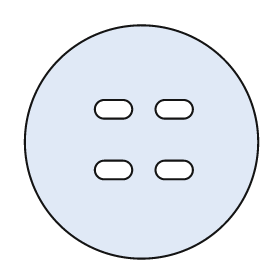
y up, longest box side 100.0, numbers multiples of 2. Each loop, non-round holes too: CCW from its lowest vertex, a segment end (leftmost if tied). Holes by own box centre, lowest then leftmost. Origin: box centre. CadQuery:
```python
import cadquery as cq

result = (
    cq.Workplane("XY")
    .moveTo(0.0, 0.0)
    .circle(50.0)
    .moveTo(-16.0, -16.0)
    .lineTo(-8.0, -16.0)
    .threePointArc((-4.0, -12.0), (-8.0, -8.0))
    .lineTo(-16.0, -8.0)
    .threePointArc((-20.0, -12.0), (-16.0, -16.0))
    .close()
    .moveTo(10.0, -16.0)
    .lineTo(18.0, -16.0)
    .threePointArc((22.0, -12.0), (18.0, -8.0))
    .lineTo(10.0, -8.0)
    .threePointArc((6.0, -12.0), (10.0, -16.0))
    .close()
    .moveTo(-16.0, 10.0)
    .lineTo(-8.0, 10.0)
    .threePointArc((-4.0, 14.0), (-8.0, 18.0))
    .lineTo(-16.0, 18.0)
    .threePointArc((-20.0, 14.0), (-16.0, 10.0))
    .close()
    .moveTo(10.0, 10.0)
    .lineTo(18.0, 10.0)
    .threePointArc((22.0, 14.0), (18.0, 18.0))
    .lineTo(10.0, 18.0)
    .threePointArc((6.0, 14.0), (10.0, 10.0))
    .close()
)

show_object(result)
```